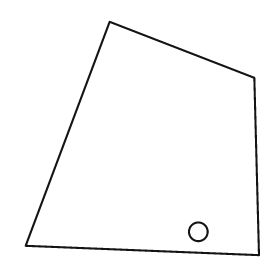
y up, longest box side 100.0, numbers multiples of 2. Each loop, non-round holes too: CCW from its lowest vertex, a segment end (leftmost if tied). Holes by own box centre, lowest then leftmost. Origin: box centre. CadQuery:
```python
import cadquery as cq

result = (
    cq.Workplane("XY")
    .moveTo(50.0, -50.0)
    .lineTo(48.0, 26.0)
    .lineTo(-14.0, 50.0)
    .lineTo(-50.0, -46.0)
    .close()
    .moveTo(24.0, -40.0)
    .circle(4.0)
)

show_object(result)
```